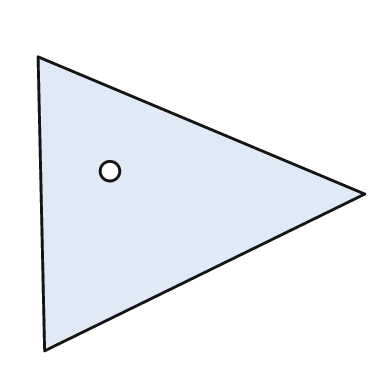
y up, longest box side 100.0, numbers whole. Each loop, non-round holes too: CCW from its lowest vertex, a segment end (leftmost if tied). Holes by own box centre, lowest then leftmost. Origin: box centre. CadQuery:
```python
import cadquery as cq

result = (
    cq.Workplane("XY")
    .moveTo(-48.0, -45.0)
    .lineTo(50.0, 3.0)
    .lineTo(-50.0, 45.0)
    .close()
    .moveTo(-28.0, 10.0)
    .circle(3.0)
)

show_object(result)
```